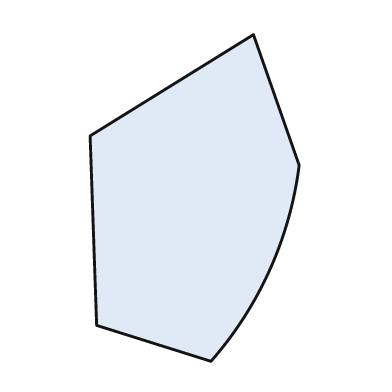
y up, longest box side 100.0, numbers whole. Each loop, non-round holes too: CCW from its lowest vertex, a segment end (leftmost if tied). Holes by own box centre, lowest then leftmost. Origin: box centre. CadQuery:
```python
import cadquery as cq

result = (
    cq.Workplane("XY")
    .moveTo(5.0, -50.0)
    .threePointArc((23.0, -22.0), (32.0, 10.0))
    .lineTo(18.0, 50.0)
    .lineTo(-32.0, 19.0)
    .lineTo(-30.0, -39.0)
    .close()
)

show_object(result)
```